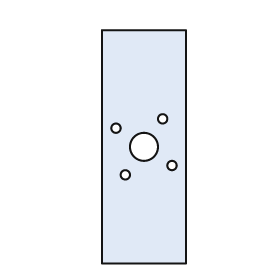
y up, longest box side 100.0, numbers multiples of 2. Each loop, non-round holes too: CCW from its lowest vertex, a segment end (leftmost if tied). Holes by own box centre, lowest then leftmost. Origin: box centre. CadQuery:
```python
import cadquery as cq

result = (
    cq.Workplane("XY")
    .moveTo(-18.0, -50.0)
    .lineTo(18.0, -50.0)
    .lineTo(18.0, 50.0)
    .lineTo(-18.0, 50.0)
    .close()
    .moveTo(-8.0, -12.0)
    .circle(2.0)
    .moveTo(12.0, -8.0)
    .circle(2.0)
    .moveTo(0.0, 0.0)
    .circle(6.0)
    .moveTo(-12.0, 8.0)
    .circle(2.0)
    .moveTo(8.0, 12.0)
    .circle(2.0)
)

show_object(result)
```